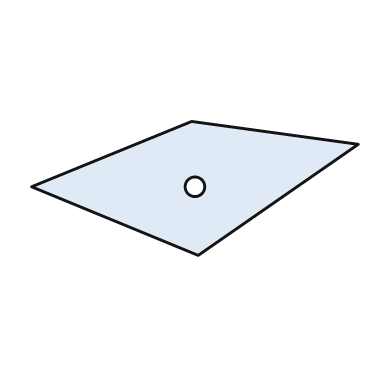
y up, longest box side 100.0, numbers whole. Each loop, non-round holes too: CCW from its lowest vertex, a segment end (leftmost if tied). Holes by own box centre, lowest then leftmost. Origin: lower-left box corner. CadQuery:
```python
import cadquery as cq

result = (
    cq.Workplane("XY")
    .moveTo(51.0, 0.0)
    .lineTo(100.0, 34.0)
    .lineTo(49.0, 41.0)
    .lineTo(0.0, 21.0)
    .close()
    .moveTo(50.0, 21.0)
    .circle(3.0)
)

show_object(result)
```